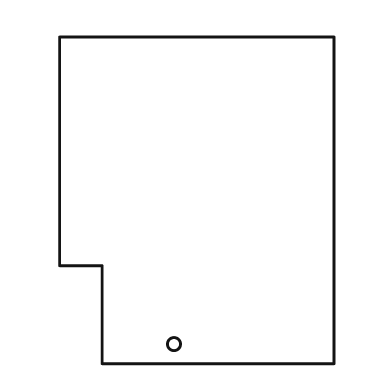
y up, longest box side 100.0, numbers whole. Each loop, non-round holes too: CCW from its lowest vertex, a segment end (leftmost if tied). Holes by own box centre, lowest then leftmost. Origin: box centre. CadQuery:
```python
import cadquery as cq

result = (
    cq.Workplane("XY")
    .moveTo(-29.0, -50.0)
    .lineTo(42.0, -50.0)
    .lineTo(42.0, 50.0)
    .lineTo(-42.0, 50.0)
    .lineTo(-42.0, -20.0)
    .lineTo(-29.0, -20.0)
    .close()
    .moveTo(-7.0, -44.0)
    .circle(2.0)
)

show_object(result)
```